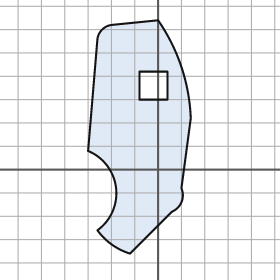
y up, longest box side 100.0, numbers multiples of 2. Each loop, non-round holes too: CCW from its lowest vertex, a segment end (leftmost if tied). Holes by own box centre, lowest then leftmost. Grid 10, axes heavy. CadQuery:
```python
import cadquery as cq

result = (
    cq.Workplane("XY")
    .moveTo(-12.0, -36.0)
    .lineTo(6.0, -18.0)
    .threePointArc((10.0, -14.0), (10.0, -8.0))
    .lineTo(14.0, 22.0)
    .threePointArc((10.0, 44.0), (0.0, 64.0))
    .lineTo(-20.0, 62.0)
    .threePointArc((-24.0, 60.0), (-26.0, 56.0))
    .lineTo(-30.0, 8.0)
    .threePointArc((-18.0, -8.0), (-26.0, -26.0))
    .threePointArc((-20.0, -32.0), (-12.0, -36.0))
    .close()
    .moveTo(-8.0, 30.0)
    .lineTo(4.0, 30.0)
    .lineTo(4.0, 42.0)
    .lineTo(-8.0, 42.0)
    .close()
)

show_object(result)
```